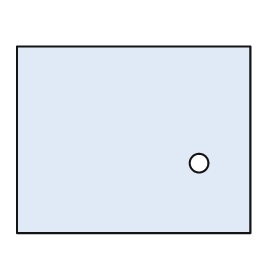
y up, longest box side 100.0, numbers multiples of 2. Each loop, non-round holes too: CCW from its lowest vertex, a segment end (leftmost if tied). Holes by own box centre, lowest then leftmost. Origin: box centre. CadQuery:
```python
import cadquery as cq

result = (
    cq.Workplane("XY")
    .moveTo(-50.0, -40.0)
    .lineTo(50.0, -40.0)
    .lineTo(50.0, 40.0)
    .lineTo(-50.0, 40.0)
    .close()
    .moveTo(28.0, -10.0)
    .circle(4.0)
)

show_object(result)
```